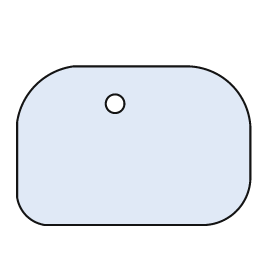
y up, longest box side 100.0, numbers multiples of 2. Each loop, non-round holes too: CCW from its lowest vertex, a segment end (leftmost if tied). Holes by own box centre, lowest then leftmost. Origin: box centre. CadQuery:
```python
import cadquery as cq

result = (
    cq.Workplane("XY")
    .moveTo(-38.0, -34.0)
    .lineTo(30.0, -34.0)
    .threePointArc((44.0, -28.0), (50.0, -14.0))
    .lineTo(50.0, 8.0)
    .threePointArc((42.0, 26.0), (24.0, 34.0))
    .lineTo(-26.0, 34.0)
    .threePointArc((-42.0, 26.0), (-50.0, 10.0))
    .lineTo(-50.0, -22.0)
    .threePointArc((-46.0, -30.0), (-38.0, -34.0))
    .close()
    .moveTo(-8.0, 18.0)
    .circle(4.0)
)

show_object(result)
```